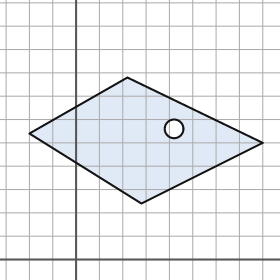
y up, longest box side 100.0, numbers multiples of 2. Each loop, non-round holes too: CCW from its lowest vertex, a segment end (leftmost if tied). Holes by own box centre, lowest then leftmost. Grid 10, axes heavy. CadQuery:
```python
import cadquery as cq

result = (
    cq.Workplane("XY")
    .moveTo(28.0, 24.0)
    .lineTo(80.0, 50.0)
    .lineTo(22.0, 78.0)
    .lineTo(-20.0, 54.0)
    .close()
    .moveTo(42.0, 56.0)
    .circle(4.0)
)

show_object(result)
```